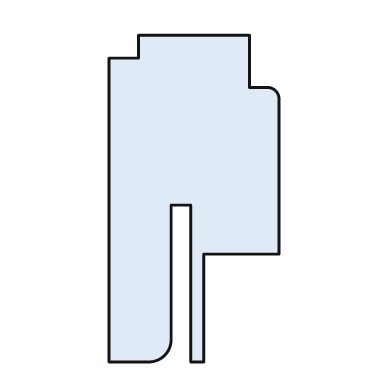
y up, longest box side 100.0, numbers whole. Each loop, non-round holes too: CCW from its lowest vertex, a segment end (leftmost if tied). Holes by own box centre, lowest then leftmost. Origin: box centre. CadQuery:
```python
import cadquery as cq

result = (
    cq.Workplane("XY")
    .moveTo(-26.0, -50.0)
    .lineTo(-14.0, -50.0)
    .threePointArc((-9.0, -48.0), (-7.0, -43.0))
    .lineTo(-7.0, -2.0)
    .lineTo(-1.0, -2.0)
    .lineTo(-1.0, -50.0)
    .lineTo(3.0, -50.0)
    .lineTo(3.0, -17.0)
    .lineTo(26.0, -17.0)
    .lineTo(26.0, 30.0)
    .threePointArc((25.0, 33.0), (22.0, 34.0))
    .lineTo(17.0, 34.0)
    .lineTo(17.0, 50.0)
    .lineTo(-17.0, 50.0)
    .lineTo(-17.0, 43.0)
    .lineTo(-26.0, 43.0)
    .close()
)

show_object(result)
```